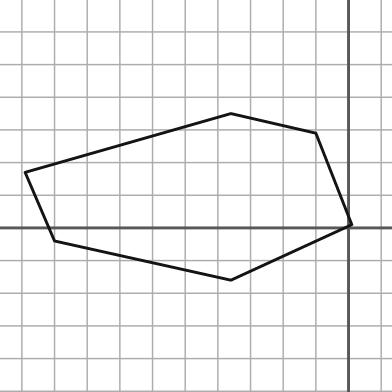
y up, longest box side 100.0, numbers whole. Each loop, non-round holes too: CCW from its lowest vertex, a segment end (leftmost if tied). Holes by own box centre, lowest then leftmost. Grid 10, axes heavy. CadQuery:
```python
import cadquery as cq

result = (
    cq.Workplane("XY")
    .moveTo(-36.0, -16.0)
    .lineTo(1.0, 1.0)
    .lineTo(-10.0, 29.0)
    .lineTo(-36.0, 35.0)
    .lineTo(-99.0, 17.0)
    .lineTo(-90.0, -4.0)
    .close()
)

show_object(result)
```